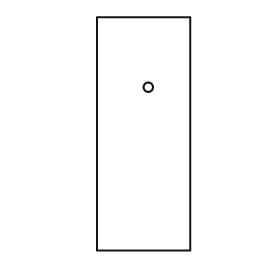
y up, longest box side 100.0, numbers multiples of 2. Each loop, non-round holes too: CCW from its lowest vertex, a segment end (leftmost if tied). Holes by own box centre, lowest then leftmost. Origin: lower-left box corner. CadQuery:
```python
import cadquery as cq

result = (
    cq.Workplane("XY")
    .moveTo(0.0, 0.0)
    .lineTo(40.0, 0.0)
    .lineTo(40.0, 100.0)
    .lineTo(0.0, 100.0)
    .close()
    .moveTo(22.0, 70.0)
    .circle(2.0)
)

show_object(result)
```